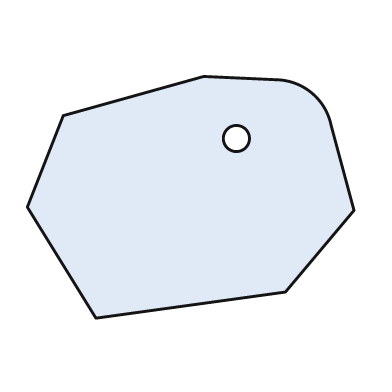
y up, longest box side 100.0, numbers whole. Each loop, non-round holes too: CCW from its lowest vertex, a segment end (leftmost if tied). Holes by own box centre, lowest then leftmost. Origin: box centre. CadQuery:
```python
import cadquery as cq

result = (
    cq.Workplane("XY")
    .moveTo(-29.0, -37.0)
    .lineTo(29.0, -29.0)
    .lineTo(50.0, -4.0)
    .lineTo(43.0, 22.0)
    .threePointArc((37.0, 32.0), (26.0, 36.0))
    .lineTo(4.0, 37.0)
    .lineTo(-39.0, 25.0)
    .lineTo(-50.0, -3.0)
    .close()
    .moveTo(14.0, 18.0)
    .circle(4.0)
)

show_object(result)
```